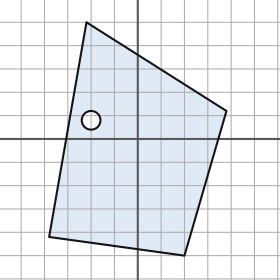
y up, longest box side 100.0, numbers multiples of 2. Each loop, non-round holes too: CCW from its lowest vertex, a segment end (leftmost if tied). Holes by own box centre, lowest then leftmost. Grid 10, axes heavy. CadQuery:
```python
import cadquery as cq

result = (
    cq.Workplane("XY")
    .moveTo(20.0, -50.0)
    .lineTo(38.0, 12.0)
    .lineTo(-22.0, 50.0)
    .lineTo(-38.0, -42.0)
    .close()
    .moveTo(-20.0, 8.0)
    .circle(4.0)
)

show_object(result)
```